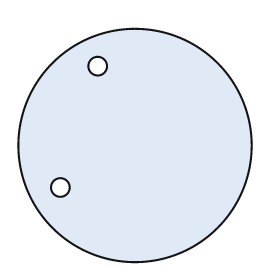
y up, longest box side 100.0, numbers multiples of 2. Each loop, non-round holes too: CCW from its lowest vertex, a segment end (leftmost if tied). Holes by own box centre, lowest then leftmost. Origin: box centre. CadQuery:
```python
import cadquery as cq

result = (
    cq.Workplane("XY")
    .moveTo(0.0, 0.0)
    .circle(50.0)
    .moveTo(-32.0, -18.0)
    .circle(4.0)
    .moveTo(-16.0, 34.0)
    .circle(4.0)
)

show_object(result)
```